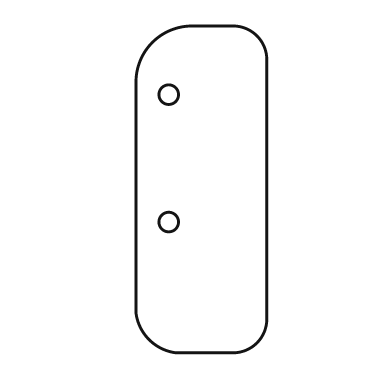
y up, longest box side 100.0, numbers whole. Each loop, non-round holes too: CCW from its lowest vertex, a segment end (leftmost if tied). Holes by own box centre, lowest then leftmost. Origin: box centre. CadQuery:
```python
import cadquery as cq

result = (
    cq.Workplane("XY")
    .moveTo(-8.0, -50.0)
    .lineTo(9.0, -50.0)
    .threePointArc((17.0, -47.0), (20.0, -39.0))
    .lineTo(20.0, 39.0)
    .threePointArc((17.0, 47.0), (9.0, 50.0))
    .lineTo(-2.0, 50.0)
    .threePointArc((-15.0, 45.0), (-20.0, 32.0))
    .lineTo(-20.0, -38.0)
    .threePointArc((-16.0, -46.0), (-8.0, -50.0))
    .close()
    .moveTo(-10.0, -10.0)
    .circle(3.0)
    .moveTo(-10.0, 29.0)
    .circle(3.0)
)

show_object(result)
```